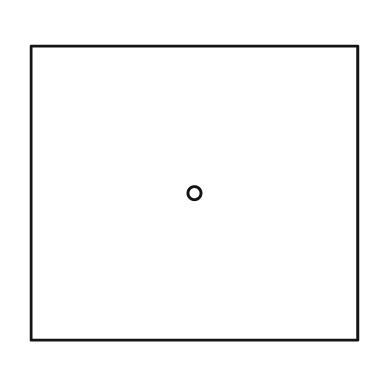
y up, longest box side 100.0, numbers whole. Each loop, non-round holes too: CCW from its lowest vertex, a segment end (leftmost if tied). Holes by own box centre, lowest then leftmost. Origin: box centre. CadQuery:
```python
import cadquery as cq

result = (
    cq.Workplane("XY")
    .moveTo(-50.0, -45.0)
    .lineTo(50.0, -45.0)
    .lineTo(50.0, 45.0)
    .lineTo(-50.0, 45.0)
    .close()
    .moveTo(0.0, 0.0)
    .circle(2.0)
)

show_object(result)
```